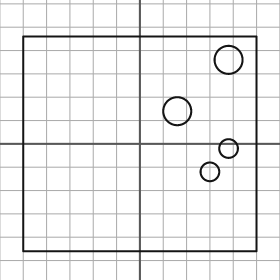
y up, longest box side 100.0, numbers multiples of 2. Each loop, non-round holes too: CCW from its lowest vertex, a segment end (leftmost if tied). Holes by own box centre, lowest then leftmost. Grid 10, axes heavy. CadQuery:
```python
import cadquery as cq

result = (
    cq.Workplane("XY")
    .moveTo(-50.0, -46.0)
    .lineTo(50.0, -46.0)
    .lineTo(50.0, 46.0)
    .lineTo(-50.0, 46.0)
    .close()
    .moveTo(30.0, -12.0)
    .circle(4.0)
    .moveTo(38.0, -2.0)
    .circle(4.0)
    .moveTo(16.0, 14.0)
    .circle(6.0)
    .moveTo(38.0, 36.0)
    .circle(6.0)
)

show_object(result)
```